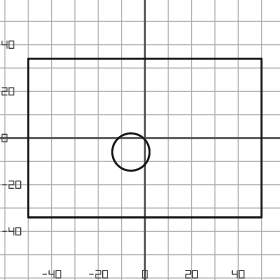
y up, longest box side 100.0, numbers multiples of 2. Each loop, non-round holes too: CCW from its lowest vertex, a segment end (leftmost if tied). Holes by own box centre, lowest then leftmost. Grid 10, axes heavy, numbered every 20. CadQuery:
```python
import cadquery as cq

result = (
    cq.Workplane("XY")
    .moveTo(-50.0, -34.0)
    .lineTo(50.0, -34.0)
    .lineTo(50.0, 34.0)
    .lineTo(-50.0, 34.0)
    .close()
    .moveTo(-6.0, -6.0)
    .circle(8.0)
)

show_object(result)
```